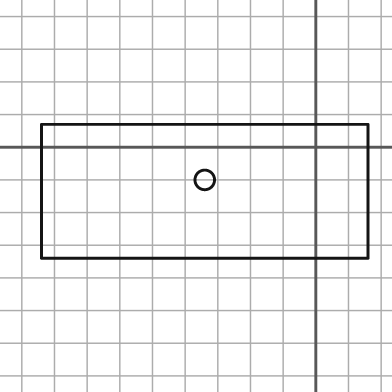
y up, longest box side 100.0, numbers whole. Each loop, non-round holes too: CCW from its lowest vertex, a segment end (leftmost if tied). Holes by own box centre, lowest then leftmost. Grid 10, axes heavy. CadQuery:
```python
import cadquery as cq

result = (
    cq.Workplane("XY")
    .moveTo(-84.0, -34.0)
    .lineTo(16.0, -34.0)
    .lineTo(16.0, 7.0)
    .lineTo(-84.0, 7.0)
    .close()
    .moveTo(-34.0, -10.0)
    .circle(3.0)
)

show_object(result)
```